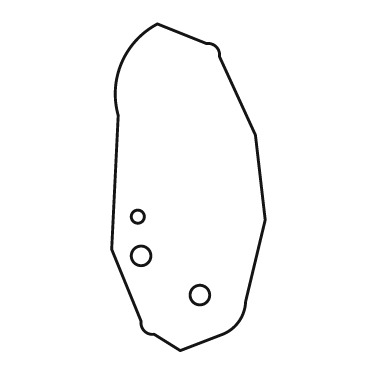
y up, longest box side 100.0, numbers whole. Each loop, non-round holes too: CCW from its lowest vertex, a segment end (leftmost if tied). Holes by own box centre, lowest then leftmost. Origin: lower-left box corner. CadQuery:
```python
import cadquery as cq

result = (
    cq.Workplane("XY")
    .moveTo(21.0, 0.0)
    .lineTo(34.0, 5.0)
    .threePointArc((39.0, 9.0), (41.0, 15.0))
    .lineTo(47.0, 40.0)
    .lineTo(44.0, 66.0)
    .lineTo(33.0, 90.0)
    .threePointArc((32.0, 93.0), (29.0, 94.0))
    .lineTo(14.0, 100.0)
    .threePointArc((3.0, 88.0), (2.0, 72.0))
    .lineTo(0.0, 31.0)
    .lineTo(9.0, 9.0)
    .threePointArc((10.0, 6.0), (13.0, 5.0))
    .close()
    .moveTo(27.0, 17.0)
    .circle(3.0)
    .moveTo(9.0, 29.0)
    .circle(3.0)
    .moveTo(8.0, 41.0)
    .circle(2.0)
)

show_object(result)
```